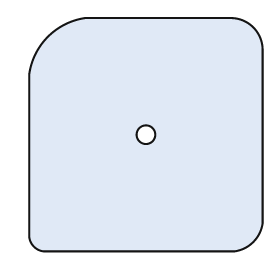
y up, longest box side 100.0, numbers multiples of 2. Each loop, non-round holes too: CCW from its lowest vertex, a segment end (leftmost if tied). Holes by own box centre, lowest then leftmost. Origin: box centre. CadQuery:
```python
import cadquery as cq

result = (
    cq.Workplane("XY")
    .moveTo(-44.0, -50.0)
    .lineTo(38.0, -50.0)
    .threePointArc((46.0, -46.0), (50.0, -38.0))
    .lineTo(50.0, 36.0)
    .threePointArc((46.0, 46.0), (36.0, 50.0))
    .lineTo(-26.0, 50.0)
    .threePointArc((-42.0, 42.0), (-50.0, 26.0))
    .lineTo(-50.0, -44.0)
    .threePointArc((-48.0, -48.0), (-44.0, -50.0))
    .close()
    .moveTo(0.0, 0.0)
    .circle(4.0)
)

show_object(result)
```